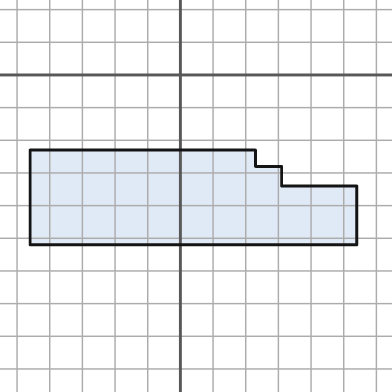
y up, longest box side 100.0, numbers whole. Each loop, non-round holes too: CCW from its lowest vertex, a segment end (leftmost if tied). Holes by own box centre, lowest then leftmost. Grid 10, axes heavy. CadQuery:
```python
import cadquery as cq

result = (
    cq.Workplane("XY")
    .moveTo(-46.0, -52.0)
    .lineTo(54.0, -52.0)
    .lineTo(54.0, -34.0)
    .lineTo(31.0, -34.0)
    .lineTo(31.0, -28.0)
    .lineTo(23.0, -28.0)
    .lineTo(23.0, -23.0)
    .lineTo(-46.0, -23.0)
    .close()
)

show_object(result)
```